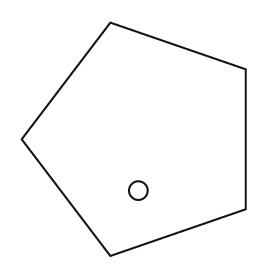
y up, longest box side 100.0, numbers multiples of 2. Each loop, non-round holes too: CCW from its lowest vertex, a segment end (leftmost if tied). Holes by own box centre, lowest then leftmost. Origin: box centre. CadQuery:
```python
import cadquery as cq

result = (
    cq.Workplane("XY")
    .moveTo(-10.0, -50.0)
    .lineTo(48.0, -30.0)
    .lineTo(48.0, 30.0)
    .lineTo(-10.0, 50.0)
    .lineTo(-48.0, 0.0)
    .close()
    .moveTo(2.0, -22.0)
    .circle(4.0)
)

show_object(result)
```